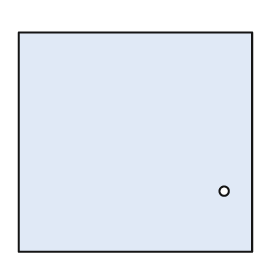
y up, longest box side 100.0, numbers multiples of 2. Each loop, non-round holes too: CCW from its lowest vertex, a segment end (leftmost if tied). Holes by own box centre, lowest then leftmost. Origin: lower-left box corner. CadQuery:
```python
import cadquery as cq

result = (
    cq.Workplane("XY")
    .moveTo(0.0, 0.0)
    .lineTo(100.0, 0.0)
    .lineTo(100.0, 94.0)
    .lineTo(0.0, 94.0)
    .close()
    .moveTo(88.0, 26.0)
    .circle(2.0)
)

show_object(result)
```